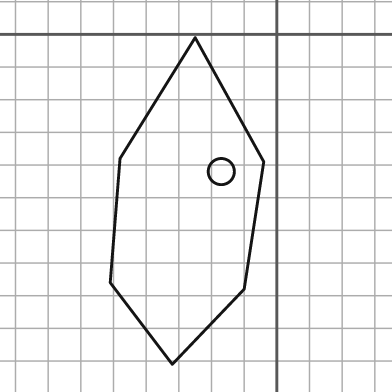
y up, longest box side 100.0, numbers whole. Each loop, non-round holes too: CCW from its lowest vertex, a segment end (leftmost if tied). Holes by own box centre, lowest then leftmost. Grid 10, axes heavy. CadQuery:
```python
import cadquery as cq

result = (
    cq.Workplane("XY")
    .moveTo(-32.0, -101.0)
    .lineTo(-10.0, -78.0)
    .lineTo(-4.0, -39.0)
    .lineTo(-25.0, -1.0)
    .lineTo(-48.0, -38.0)
    .lineTo(-51.0, -76.0)
    .close()
    .moveTo(-17.0, -42.0)
    .circle(4.0)
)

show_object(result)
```